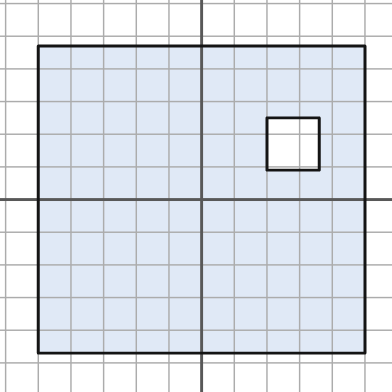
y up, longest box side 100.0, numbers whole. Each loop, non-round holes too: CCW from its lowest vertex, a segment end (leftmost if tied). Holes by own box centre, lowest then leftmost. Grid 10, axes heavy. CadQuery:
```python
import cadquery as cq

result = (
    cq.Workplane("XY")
    .moveTo(-50.0, -47.0)
    .lineTo(50.0, -47.0)
    .lineTo(50.0, 47.0)
    .lineTo(-50.0, 47.0)
    .close()
    .moveTo(20.0, 9.0)
    .lineTo(36.0, 9.0)
    .lineTo(36.0, 25.0)
    .lineTo(20.0, 25.0)
    .close()
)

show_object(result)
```